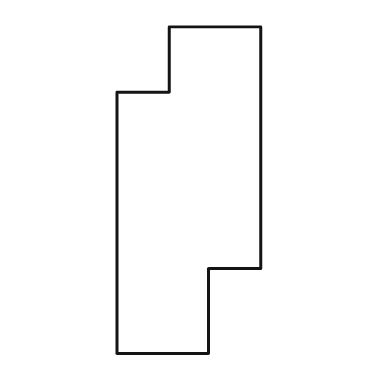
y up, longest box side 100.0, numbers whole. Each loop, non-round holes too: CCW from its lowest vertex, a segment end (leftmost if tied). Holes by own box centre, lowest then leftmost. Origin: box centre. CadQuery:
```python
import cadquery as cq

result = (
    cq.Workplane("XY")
    .moveTo(-22.0, -50.0)
    .lineTo(6.0, -50.0)
    .lineTo(6.0, -24.0)
    .lineTo(22.0, -24.0)
    .lineTo(22.0, 50.0)
    .lineTo(-6.0, 50.0)
    .lineTo(-6.0, 30.0)
    .lineTo(-22.0, 30.0)
    .close()
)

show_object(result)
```